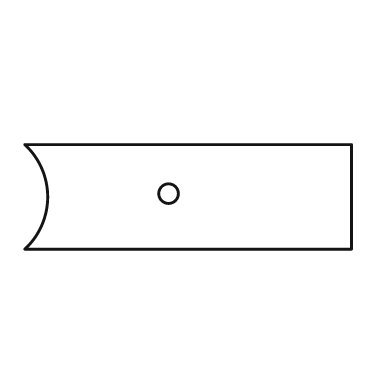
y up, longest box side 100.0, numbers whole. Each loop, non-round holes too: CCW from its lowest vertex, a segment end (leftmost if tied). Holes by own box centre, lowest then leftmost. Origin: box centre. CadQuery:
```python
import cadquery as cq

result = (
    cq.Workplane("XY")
    .moveTo(-50.0, -16.0)
    .lineTo(50.0, -16.0)
    .lineTo(50.0, 16.0)
    .lineTo(-50.0, 16.0)
    .threePointArc((-43.0, 0.0), (-50.0, -16.0))
    .close()
    .moveTo(-6.0, 1.0)
    .circle(3.0)
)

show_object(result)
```